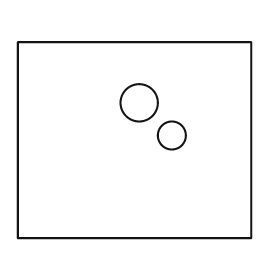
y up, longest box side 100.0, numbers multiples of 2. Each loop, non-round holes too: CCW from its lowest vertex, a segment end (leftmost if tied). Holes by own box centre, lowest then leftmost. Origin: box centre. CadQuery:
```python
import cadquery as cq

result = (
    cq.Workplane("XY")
    .moveTo(-50.0, -42.0)
    .lineTo(50.0, -42.0)
    .lineTo(50.0, 42.0)
    .lineTo(-50.0, 42.0)
    .close()
    .moveTo(16.0, 2.0)
    .circle(6.0)
    .moveTo(2.0, 16.0)
    .circle(8.0)
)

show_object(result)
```